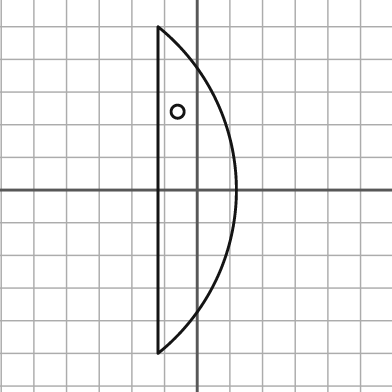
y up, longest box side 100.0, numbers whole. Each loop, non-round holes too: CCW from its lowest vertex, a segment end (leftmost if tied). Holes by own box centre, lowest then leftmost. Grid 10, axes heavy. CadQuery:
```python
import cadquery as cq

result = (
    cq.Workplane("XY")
    .moveTo(-12.0, -50.0)
    .threePointArc((12.0, 0.0), (-12.0, 50.0))
    .close()
    .moveTo(-6.0, 24.0)
    .circle(2.0)
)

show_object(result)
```